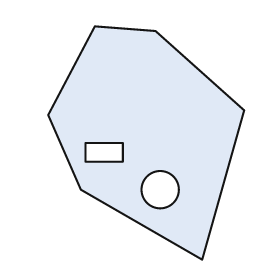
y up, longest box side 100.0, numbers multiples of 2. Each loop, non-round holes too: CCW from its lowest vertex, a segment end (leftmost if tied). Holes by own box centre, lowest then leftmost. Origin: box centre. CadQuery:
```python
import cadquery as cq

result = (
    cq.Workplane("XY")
    .moveTo(24.0, -50.0)
    .lineTo(42.0, 14.0)
    .lineTo(4.0, 48.0)
    .lineTo(-22.0, 50.0)
    .lineTo(-42.0, 12.0)
    .lineTo(-28.0, -20.0)
    .close()
    .moveTo(6.0, -20.0)
    .circle(8.0)
    .moveTo(-26.0, -8.0)
    .lineTo(-10.0, -8.0)
    .lineTo(-10.0, 0.0)
    .lineTo(-26.0, 0.0)
    .close()
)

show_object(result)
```